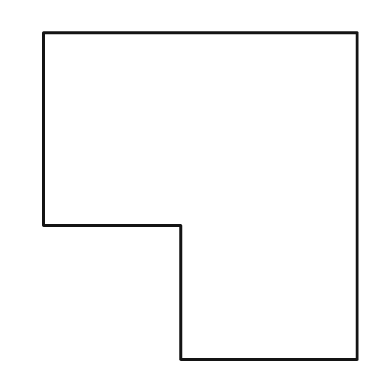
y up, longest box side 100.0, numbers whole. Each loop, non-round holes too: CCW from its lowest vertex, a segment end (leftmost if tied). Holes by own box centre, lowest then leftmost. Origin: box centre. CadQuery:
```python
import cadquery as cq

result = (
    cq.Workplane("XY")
    .moveTo(-6.0, -50.0)
    .lineTo(48.0, -50.0)
    .lineTo(48.0, 50.0)
    .lineTo(-48.0, 50.0)
    .lineTo(-48.0, -9.0)
    .lineTo(-6.0, -9.0)
    .close()
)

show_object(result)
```